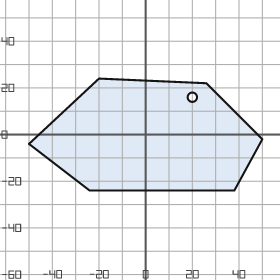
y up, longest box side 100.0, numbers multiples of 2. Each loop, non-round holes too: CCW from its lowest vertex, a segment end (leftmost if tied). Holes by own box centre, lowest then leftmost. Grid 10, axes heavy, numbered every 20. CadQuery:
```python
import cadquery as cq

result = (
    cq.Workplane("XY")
    .moveTo(-24.0, -24.0)
    .lineTo(38.0, -24.0)
    .lineTo(50.0, -2.0)
    .lineTo(26.0, 22.0)
    .lineTo(-20.0, 24.0)
    .lineTo(-50.0, -4.0)
    .close()
    .moveTo(20.0, 16.0)
    .circle(2.0)
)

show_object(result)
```